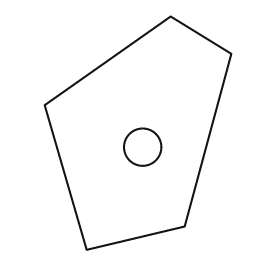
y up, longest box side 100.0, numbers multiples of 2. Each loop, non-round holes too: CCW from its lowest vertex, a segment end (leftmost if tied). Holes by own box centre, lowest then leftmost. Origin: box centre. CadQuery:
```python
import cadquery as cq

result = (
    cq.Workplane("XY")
    .moveTo(-22.0, -50.0)
    .lineTo(20.0, -40.0)
    .lineTo(40.0, 34.0)
    .lineTo(14.0, 50.0)
    .lineTo(-40.0, 12.0)
    .close()
    .moveTo(2.0, -6.0)
    .circle(8.0)
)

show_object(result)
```